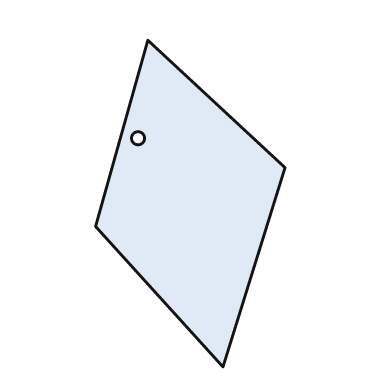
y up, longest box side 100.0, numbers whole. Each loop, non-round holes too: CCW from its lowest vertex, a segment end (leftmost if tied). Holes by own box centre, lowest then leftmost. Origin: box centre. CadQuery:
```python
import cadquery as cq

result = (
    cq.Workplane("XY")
    .moveTo(10.0, -50.0)
    .lineTo(29.0, 11.0)
    .lineTo(-13.0, 50.0)
    .lineTo(-29.0, -7.0)
    .close()
    .moveTo(-16.0, 20.0)
    .circle(2.0)
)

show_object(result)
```